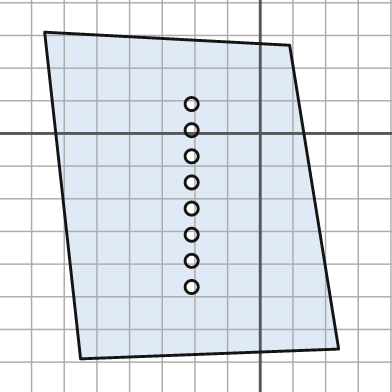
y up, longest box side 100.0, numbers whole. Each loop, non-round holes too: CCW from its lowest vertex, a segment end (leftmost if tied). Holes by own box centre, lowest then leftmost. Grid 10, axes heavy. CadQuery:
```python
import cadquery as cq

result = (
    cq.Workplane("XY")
    .moveTo(-55.0, -69.0)
    .lineTo(24.0, -66.0)
    .lineTo(9.0, 27.0)
    .lineTo(-66.0, 31.0)
    .close()
    .moveTo(-21.0, -47.0)
    .circle(2.0)
    .moveTo(-21.0, -39.0)
    .circle(2.0)
    .moveTo(-21.0, -31.0)
    .circle(2.0)
    .moveTo(-21.0, -23.0)
    .circle(2.0)
    .moveTo(-21.0, -15.0)
    .circle(2.0)
    .moveTo(-21.0, -7.0)
    .circle(2.0)
    .moveTo(-21.0, 1.0)
    .circle(2.0)
    .moveTo(-21.0, 9.0)
    .circle(2.0)
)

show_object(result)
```